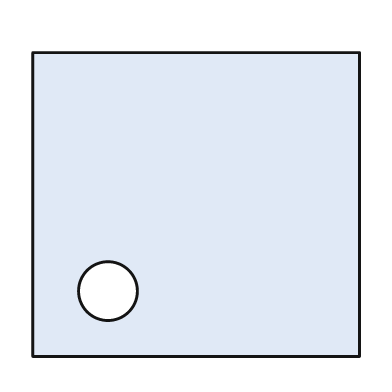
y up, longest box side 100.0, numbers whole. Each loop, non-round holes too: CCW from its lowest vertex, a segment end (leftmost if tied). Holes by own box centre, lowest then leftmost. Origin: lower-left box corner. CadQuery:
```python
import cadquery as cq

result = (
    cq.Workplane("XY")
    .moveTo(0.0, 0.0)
    .lineTo(100.0, 0.0)
    .lineTo(100.0, 93.0)
    .lineTo(0.0, 93.0)
    .close()
    .moveTo(23.0, 20.0)
    .circle(9.0)
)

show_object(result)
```